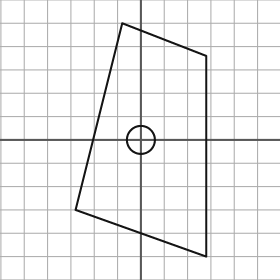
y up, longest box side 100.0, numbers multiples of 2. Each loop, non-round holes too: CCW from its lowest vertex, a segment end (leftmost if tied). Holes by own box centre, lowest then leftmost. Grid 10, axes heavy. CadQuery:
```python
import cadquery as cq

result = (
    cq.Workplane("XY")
    .moveTo(28.0, -50.0)
    .lineTo(28.0, 36.0)
    .lineTo(-8.0, 50.0)
    .lineTo(-28.0, -30.0)
    .close()
    .moveTo(0.0, 0.0)
    .circle(6.0)
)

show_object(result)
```